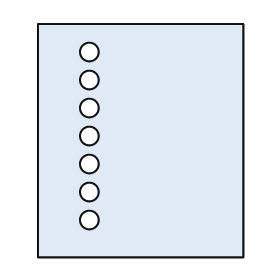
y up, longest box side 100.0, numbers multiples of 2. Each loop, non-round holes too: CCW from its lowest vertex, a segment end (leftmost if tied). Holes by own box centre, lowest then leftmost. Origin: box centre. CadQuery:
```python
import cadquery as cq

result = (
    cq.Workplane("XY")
    .moveTo(-44.0, -50.0)
    .lineTo(44.0, -50.0)
    .lineTo(44.0, 50.0)
    .lineTo(-44.0, 50.0)
    .close()
    .moveTo(-22.0, -34.0)
    .circle(4.0)
    .moveTo(-22.0, -22.0)
    .circle(4.0)
    .moveTo(-22.0, -10.0)
    .circle(4.0)
    .moveTo(-22.0, 2.0)
    .circle(4.0)
    .moveTo(-22.0, 14.0)
    .circle(4.0)
    .moveTo(-22.0, 26.0)
    .circle(4.0)
    .moveTo(-22.0, 38.0)
    .circle(4.0)
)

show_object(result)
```